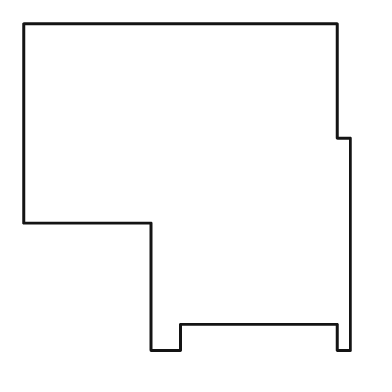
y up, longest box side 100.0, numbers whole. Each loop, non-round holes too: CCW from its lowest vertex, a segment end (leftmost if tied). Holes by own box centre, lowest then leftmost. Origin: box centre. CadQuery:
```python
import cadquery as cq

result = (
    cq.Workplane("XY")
    .moveTo(-11.0, -50.0)
    .lineTo(-2.0, -50.0)
    .lineTo(-2.0, -42.0)
    .lineTo(46.0, -42.0)
    .lineTo(46.0, -50.0)
    .lineTo(50.0, -50.0)
    .lineTo(50.0, 15.0)
    .lineTo(46.0, 15.0)
    .lineTo(46.0, 50.0)
    .lineTo(-50.0, 50.0)
    .lineTo(-50.0, -11.0)
    .lineTo(-11.0, -11.0)
    .close()
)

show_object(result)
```